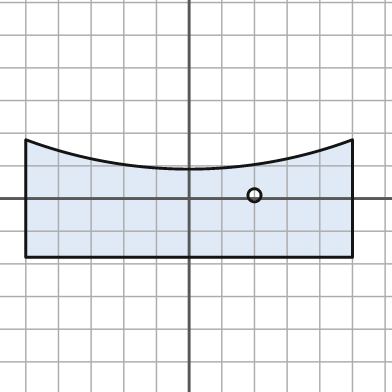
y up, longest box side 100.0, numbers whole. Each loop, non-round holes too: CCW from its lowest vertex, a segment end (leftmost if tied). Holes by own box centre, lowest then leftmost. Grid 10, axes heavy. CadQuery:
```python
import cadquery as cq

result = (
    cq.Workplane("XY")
    .moveTo(-50.0, -18.0)
    .lineTo(50.0, -18.0)
    .lineTo(50.0, 18.0)
    .threePointArc((0.0, 9.0), (-50.0, 18.0))
    .close()
    .moveTo(20.0, 1.0)
    .circle(2.0)
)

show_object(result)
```